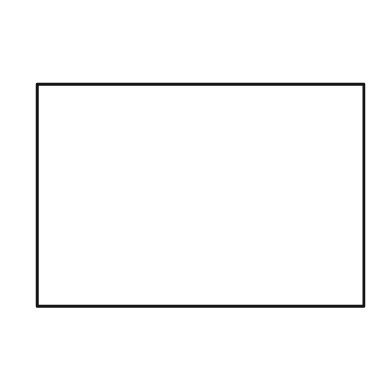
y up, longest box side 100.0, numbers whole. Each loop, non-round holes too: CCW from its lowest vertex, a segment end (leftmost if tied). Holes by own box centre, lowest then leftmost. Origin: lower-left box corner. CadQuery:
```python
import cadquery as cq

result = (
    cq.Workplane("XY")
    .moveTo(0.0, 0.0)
    .lineTo(100.0, 0.0)
    .lineTo(100.0, 68.0)
    .lineTo(0.0, 68.0)
    .close()
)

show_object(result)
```